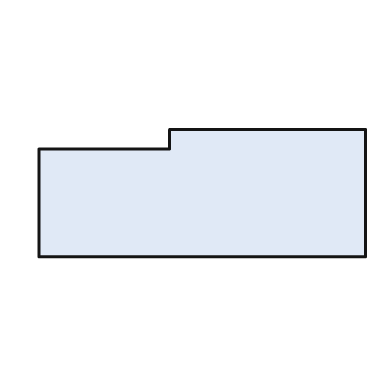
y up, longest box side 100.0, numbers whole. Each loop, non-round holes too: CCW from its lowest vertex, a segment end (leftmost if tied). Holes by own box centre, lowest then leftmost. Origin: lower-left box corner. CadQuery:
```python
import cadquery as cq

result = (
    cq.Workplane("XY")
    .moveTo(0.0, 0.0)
    .lineTo(100.0, 0.0)
    .lineTo(100.0, 39.0)
    .lineTo(40.0, 39.0)
    .lineTo(40.0, 33.0)
    .lineTo(0.0, 33.0)
    .close()
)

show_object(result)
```